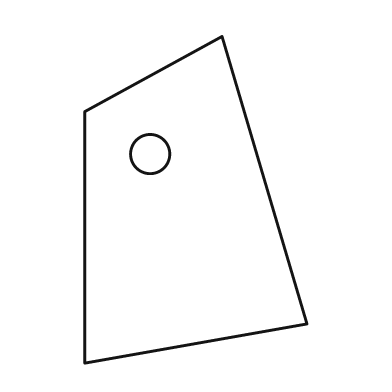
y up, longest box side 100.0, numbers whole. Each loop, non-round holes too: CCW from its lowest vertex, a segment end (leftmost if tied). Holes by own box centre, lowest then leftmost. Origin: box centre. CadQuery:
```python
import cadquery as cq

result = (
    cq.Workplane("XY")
    .moveTo(-34.0, -50.0)
    .lineTo(34.0, -38.0)
    .lineTo(8.0, 50.0)
    .lineTo(-34.0, 27.0)
    .close()
    .moveTo(-14.0, 14.0)
    .circle(6.0)
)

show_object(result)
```